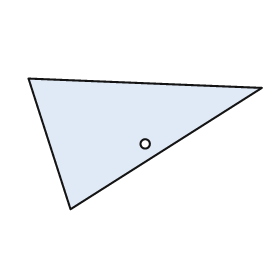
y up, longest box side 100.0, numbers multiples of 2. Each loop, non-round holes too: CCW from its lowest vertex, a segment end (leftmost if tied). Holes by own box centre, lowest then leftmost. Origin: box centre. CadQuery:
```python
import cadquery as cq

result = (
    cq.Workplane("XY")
    .moveTo(-32.0, -28.0)
    .lineTo(50.0, 24.0)
    .lineTo(-50.0, 28.0)
    .close()
    .moveTo(0.0, 0.0)
    .circle(2.0)
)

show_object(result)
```